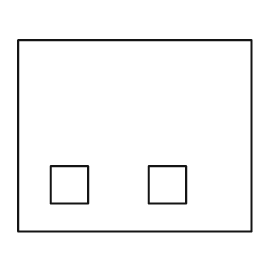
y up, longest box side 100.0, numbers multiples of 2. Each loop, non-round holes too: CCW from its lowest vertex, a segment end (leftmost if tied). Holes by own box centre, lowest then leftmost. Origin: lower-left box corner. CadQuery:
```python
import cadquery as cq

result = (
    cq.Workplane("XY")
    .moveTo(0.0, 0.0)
    .lineTo(100.0, 0.0)
    .lineTo(100.0, 82.0)
    .lineTo(0.0, 82.0)
    .close()
    .moveTo(14.0, 12.0)
    .lineTo(30.0, 12.0)
    .lineTo(30.0, 28.0)
    .lineTo(14.0, 28.0)
    .close()
    .moveTo(56.0, 12.0)
    .lineTo(72.0, 12.0)
    .lineTo(72.0, 28.0)
    .lineTo(56.0, 28.0)
    .close()
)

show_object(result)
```